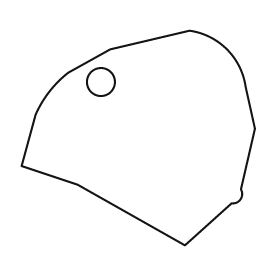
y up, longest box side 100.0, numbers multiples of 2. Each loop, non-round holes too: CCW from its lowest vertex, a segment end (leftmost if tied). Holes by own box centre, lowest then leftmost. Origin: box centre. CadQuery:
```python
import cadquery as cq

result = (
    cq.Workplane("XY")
    .moveTo(20.0, -46.0)
    .lineTo(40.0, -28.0)
    .threePointArc((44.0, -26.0), (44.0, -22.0))
    .lineTo(50.0, 4.0)
    .lineTo(46.0, 22.0)
    .threePointArc((38.0, 38.0), (22.0, 46.0))
    .lineTo(-12.0, 38.0)
    .lineTo(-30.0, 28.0)
    .threePointArc((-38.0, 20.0), (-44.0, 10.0))
    .lineTo(-50.0, -12.0)
    .lineTo(-26.0, -20.0)
    .close()
    .moveTo(-16.0, 24.0)
    .circle(6.0)
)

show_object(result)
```